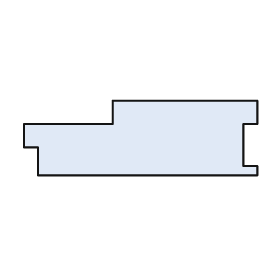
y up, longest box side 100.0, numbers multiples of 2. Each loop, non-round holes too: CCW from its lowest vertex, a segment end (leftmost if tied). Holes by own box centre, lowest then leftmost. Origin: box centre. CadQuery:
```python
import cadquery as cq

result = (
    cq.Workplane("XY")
    .moveTo(-44.0, -16.0)
    .lineTo(50.0, -16.0)
    .lineTo(50.0, -12.0)
    .lineTo(44.0, -12.0)
    .lineTo(44.0, 6.0)
    .lineTo(50.0, 6.0)
    .lineTo(50.0, 16.0)
    .lineTo(-12.0, 16.0)
    .lineTo(-12.0, 6.0)
    .lineTo(-50.0, 6.0)
    .lineTo(-50.0, -4.0)
    .lineTo(-44.0, -4.0)
    .close()
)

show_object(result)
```